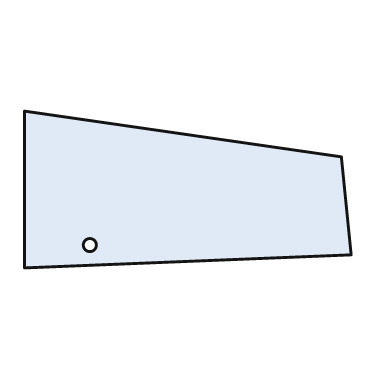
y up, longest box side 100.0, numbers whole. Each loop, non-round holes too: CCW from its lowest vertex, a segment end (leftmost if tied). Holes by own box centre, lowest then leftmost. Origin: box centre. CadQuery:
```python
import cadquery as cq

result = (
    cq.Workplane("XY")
    .moveTo(-50.0, -24.0)
    .lineTo(50.0, -20.0)
    .lineTo(47.0, 10.0)
    .lineTo(-50.0, 24.0)
    .close()
    .moveTo(-30.0, -17.0)
    .circle(2.0)
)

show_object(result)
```